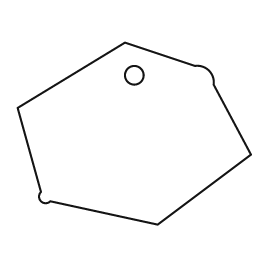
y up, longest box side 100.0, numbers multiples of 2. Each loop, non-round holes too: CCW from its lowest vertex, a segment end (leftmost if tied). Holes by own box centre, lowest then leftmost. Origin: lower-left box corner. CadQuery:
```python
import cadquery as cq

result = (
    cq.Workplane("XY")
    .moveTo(60.0, 0.0)
    .lineTo(100.0, 30.0)
    .lineTo(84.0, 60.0)
    .threePointArc((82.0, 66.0), (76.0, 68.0))
    .lineTo(46.0, 78.0)
    .lineTo(0.0, 50.0)
    .lineTo(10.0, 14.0)
    .threePointArc((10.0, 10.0), (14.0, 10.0))
    .close()
    .moveTo(50.0, 64.0)
    .circle(4.0)
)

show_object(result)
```